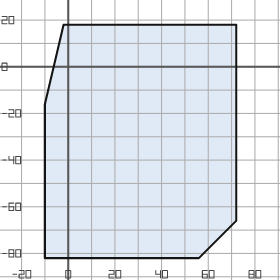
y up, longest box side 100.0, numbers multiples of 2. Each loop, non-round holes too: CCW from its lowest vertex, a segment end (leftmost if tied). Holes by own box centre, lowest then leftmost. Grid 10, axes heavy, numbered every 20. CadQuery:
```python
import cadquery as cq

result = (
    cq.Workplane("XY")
    .moveTo(-10.0, -82.0)
    .lineTo(56.0, -82.0)
    .lineTo(72.0, -66.0)
    .lineTo(72.0, 18.0)
    .lineTo(-2.0, 18.0)
    .lineTo(-10.0, -16.0)
    .close()
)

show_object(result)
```